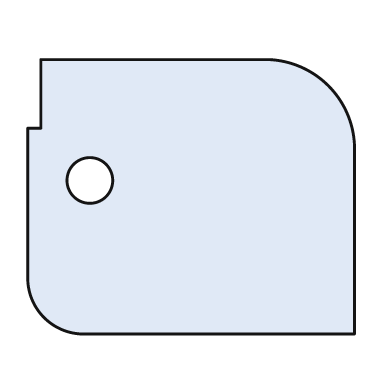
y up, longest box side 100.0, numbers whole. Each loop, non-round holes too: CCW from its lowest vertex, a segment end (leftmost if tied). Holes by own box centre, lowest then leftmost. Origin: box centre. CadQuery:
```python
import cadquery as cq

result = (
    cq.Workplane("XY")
    .moveTo(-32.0, -42.0)
    .lineTo(50.0, -42.0)
    .lineTo(50.0, 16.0)
    .threePointArc((42.0, 34.0), (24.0, 42.0))
    .lineTo(-46.0, 42.0)
    .lineTo(-46.0, 21.0)
    .lineTo(-50.0, 21.0)
    .lineTo(-50.0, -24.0)
    .threePointArc((-45.0, -37.0), (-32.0, -42.0))
    .close()
    .moveTo(-31.0, 5.0)
    .circle(7.0)
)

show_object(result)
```